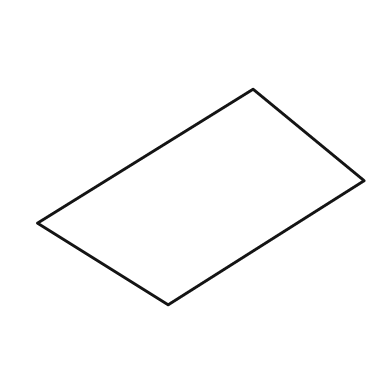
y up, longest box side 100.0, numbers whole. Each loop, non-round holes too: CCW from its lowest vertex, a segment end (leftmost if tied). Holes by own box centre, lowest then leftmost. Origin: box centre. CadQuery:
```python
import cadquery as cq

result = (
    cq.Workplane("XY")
    .moveTo(-10.0, -33.0)
    .lineTo(50.0, 5.0)
    .lineTo(16.0, 33.0)
    .lineTo(-50.0, -8.0)
    .close()
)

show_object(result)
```